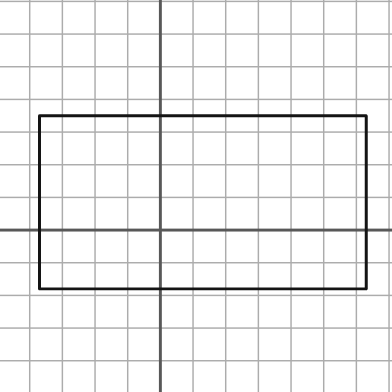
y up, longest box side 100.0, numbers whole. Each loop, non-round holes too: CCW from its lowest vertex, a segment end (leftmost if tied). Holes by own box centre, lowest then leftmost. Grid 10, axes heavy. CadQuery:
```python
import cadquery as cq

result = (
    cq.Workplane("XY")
    .moveTo(-37.0, -18.0)
    .lineTo(63.0, -18.0)
    .lineTo(63.0, 35.0)
    .lineTo(-37.0, 35.0)
    .close()
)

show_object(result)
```